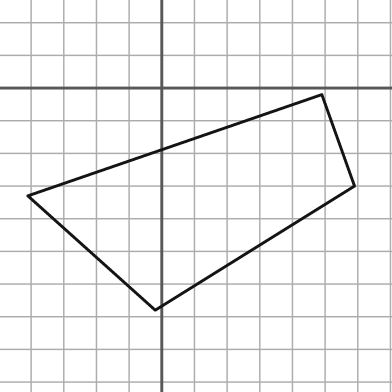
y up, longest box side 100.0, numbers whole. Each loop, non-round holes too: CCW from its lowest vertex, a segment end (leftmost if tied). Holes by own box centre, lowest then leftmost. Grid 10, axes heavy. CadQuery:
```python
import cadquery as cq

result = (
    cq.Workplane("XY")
    .moveTo(-2.0, -68.0)
    .lineTo(59.0, -30.0)
    .lineTo(49.0, -2.0)
    .lineTo(-41.0, -33.0)
    .close()
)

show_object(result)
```